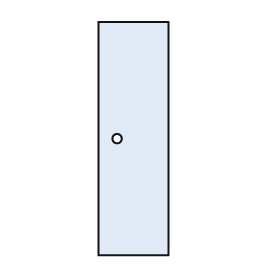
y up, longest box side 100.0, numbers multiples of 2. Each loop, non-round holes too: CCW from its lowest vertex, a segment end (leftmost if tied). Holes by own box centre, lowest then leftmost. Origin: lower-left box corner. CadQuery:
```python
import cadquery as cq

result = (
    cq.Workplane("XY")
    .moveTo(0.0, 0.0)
    .lineTo(30.0, 0.0)
    .lineTo(30.0, 100.0)
    .lineTo(0.0, 100.0)
    .close()
    .moveTo(8.0, 50.0)
    .circle(2.0)
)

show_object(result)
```